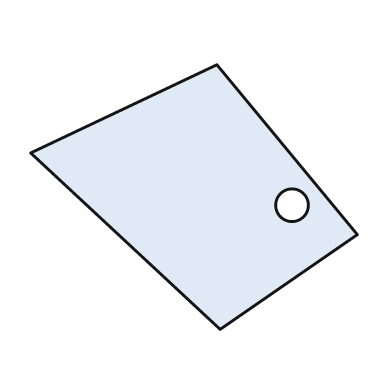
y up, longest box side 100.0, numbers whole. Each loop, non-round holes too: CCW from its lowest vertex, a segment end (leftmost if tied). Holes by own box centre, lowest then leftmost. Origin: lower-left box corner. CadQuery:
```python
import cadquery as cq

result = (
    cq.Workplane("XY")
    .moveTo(58.0, 0.0)
    .lineTo(100.0, 29.0)
    .lineTo(57.0, 81.0)
    .lineTo(0.0, 54.0)
    .close()
    .moveTo(80.0, 38.0)
    .circle(5.0)
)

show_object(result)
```